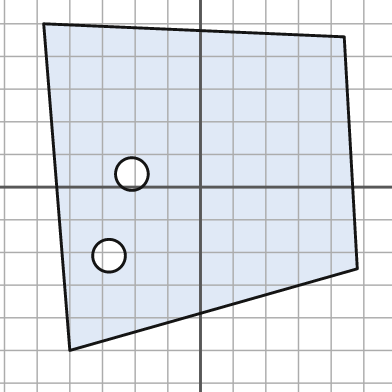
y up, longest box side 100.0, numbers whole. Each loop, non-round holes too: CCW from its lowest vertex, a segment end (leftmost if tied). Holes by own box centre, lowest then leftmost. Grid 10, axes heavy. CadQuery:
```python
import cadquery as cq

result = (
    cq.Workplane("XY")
    .moveTo(-40.0, -50.0)
    .lineTo(48.0, -25.0)
    .lineTo(44.0, 46.0)
    .lineTo(-48.0, 50.0)
    .close()
    .moveTo(-28.0, -21.0)
    .circle(5.0)
    .moveTo(-21.0, 4.0)
    .circle(5.0)
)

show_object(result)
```